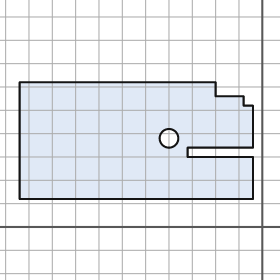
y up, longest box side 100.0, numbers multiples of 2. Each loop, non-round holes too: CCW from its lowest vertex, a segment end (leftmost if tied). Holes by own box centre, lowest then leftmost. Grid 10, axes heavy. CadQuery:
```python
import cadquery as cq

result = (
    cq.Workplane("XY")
    .moveTo(-104.0, 12.0)
    .lineTo(-4.0, 12.0)
    .lineTo(-4.0, 30.0)
    .lineTo(-32.0, 30.0)
    .lineTo(-32.0, 34.0)
    .lineTo(-4.0, 34.0)
    .lineTo(-4.0, 52.0)
    .lineTo(-8.0, 52.0)
    .lineTo(-8.0, 56.0)
    .lineTo(-20.0, 56.0)
    .lineTo(-20.0, 62.0)
    .lineTo(-104.0, 62.0)
    .close()
    .moveTo(-40.0, 38.0)
    .circle(4.0)
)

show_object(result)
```